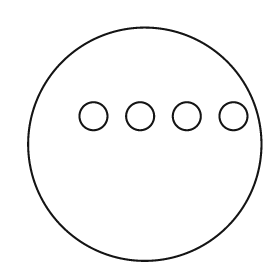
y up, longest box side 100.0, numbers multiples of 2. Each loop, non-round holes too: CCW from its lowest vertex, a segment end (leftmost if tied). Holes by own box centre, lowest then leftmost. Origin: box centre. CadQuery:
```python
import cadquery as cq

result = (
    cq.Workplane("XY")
    .moveTo(0.0, 0.0)
    .circle(50.0)
    .moveTo(-22.0, 12.0)
    .circle(6.0)
    .moveTo(-2.0, 12.0)
    .circle(6.0)
    .moveTo(18.0, 12.0)
    .circle(6.0)
    .moveTo(38.0, 12.0)
    .circle(6.0)
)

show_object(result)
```